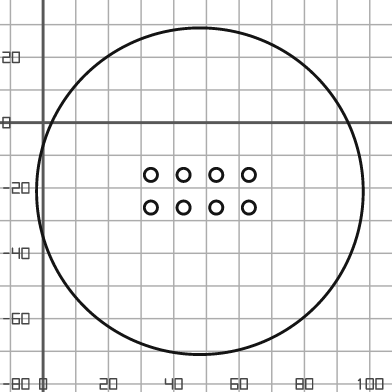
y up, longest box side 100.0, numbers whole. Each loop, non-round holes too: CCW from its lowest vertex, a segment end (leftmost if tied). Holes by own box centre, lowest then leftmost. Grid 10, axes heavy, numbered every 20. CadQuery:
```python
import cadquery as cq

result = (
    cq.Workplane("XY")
    .moveTo(48.0, -21.0)
    .circle(50.0)
    .moveTo(33.0, -26.0)
    .circle(2.0)
    .moveTo(43.0, -26.0)
    .circle(2.0)
    .moveTo(53.0, -26.0)
    .circle(2.0)
    .moveTo(63.0, -26.0)
    .circle(2.0)
    .moveTo(33.0, -16.0)
    .circle(2.0)
    .moveTo(43.0, -16.0)
    .circle(2.0)
    .moveTo(53.0, -16.0)
    .circle(2.0)
    .moveTo(63.0, -16.0)
    .circle(2.0)
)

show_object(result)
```